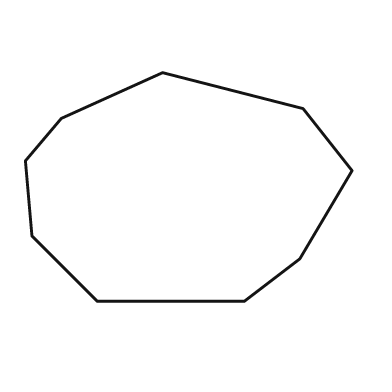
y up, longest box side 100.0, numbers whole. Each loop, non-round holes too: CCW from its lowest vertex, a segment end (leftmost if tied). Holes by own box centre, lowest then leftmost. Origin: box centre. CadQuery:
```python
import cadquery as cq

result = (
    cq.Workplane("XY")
    .moveTo(-28.0, -35.0)
    .lineTo(17.0, -35.0)
    .lineTo(34.0, -22.0)
    .lineTo(50.0, 5.0)
    .lineTo(35.0, 24.0)
    .lineTo(-8.0, 35.0)
    .lineTo(-39.0, 21.0)
    .lineTo(-50.0, 8.0)
    .lineTo(-48.0, -15.0)
    .close()
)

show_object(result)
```